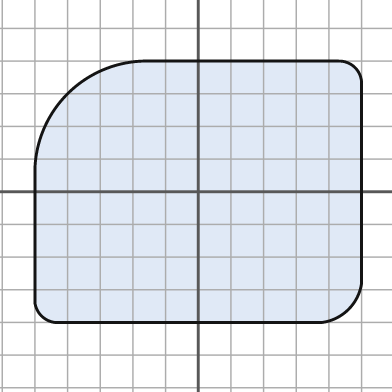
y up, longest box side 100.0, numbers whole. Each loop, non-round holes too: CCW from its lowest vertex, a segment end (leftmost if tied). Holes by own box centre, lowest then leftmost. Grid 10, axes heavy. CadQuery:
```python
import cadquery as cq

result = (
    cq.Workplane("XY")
    .moveTo(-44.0, -40.0)
    .lineTo(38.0, -40.0)
    .threePointArc((46.0, -36.0), (50.0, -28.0))
    .lineTo(50.0, 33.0)
    .threePointArc((48.0, 38.0), (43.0, 40.0))
    .lineTo(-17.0, 40.0)
    .threePointArc((-40.0, 30.0), (-50.0, 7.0))
    .lineTo(-50.0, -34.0)
    .threePointArc((-48.0, -38.0), (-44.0, -40.0))
    .close()
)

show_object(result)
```